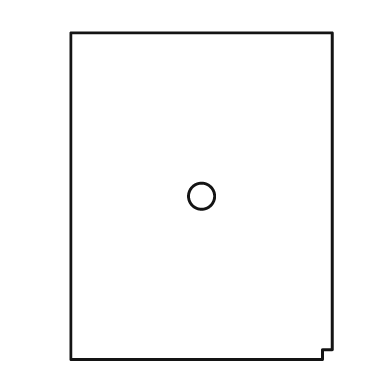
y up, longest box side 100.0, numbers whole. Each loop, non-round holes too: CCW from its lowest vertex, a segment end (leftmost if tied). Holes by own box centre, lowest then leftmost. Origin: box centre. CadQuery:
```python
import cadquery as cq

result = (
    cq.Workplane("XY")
    .moveTo(-40.0, -50.0)
    .lineTo(37.0, -50.0)
    .lineTo(37.0, -47.0)
    .lineTo(40.0, -47.0)
    .lineTo(40.0, 50.0)
    .lineTo(-40.0, 50.0)
    .close()
    .moveTo(0.0, 0.0)
    .circle(4.0)
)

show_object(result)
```